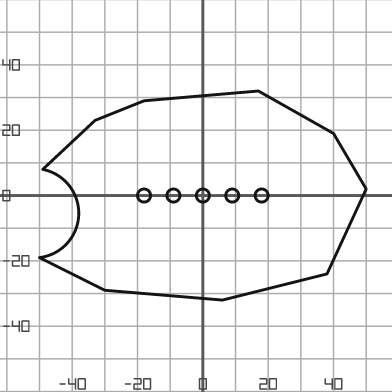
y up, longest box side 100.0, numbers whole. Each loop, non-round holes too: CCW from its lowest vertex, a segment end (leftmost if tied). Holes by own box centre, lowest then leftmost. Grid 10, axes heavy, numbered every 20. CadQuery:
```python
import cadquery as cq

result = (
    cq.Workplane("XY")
    .moveTo(6.0, -32.0)
    .lineTo(38.0, -24.0)
    .lineTo(50.0, 2.0)
    .lineTo(40.0, 19.0)
    .lineTo(17.0, 32.0)
    .lineTo(-18.0, 29.0)
    .lineTo(-33.0, 23.0)
    .lineTo(-49.0, 8.0)
    .threePointArc((-38.0, -6.0), (-50.0, -19.0))
    .lineTo(-30.0, -29.0)
    .close()
    .moveTo(-18.0, 0.0)
    .circle(2.0)
    .moveTo(-9.0, 0.0)
    .circle(2.0)
    .moveTo(0.0, 0.0)
    .circle(2.0)
    .moveTo(9.0, 0.0)
    .circle(2.0)
    .moveTo(18.0, 0.0)
    .circle(2.0)
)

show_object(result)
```